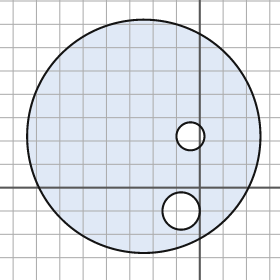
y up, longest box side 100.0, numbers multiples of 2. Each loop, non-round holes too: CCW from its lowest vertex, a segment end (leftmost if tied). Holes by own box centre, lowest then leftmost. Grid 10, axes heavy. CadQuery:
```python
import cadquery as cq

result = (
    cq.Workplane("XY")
    .moveTo(-24.0, 22.0)
    .circle(50.0)
    .moveTo(-8.0, -10.0)
    .circle(8.0)
    .moveTo(-4.0, 22.0)
    .circle(6.0)
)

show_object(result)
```